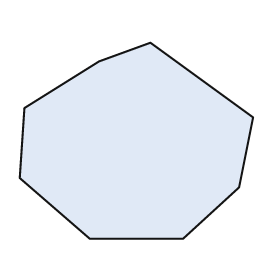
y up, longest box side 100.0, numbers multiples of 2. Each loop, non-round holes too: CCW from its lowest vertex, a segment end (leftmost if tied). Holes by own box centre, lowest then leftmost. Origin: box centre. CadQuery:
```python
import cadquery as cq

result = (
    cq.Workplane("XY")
    .moveTo(-20.0, -42.0)
    .lineTo(20.0, -42.0)
    .lineTo(44.0, -20.0)
    .lineTo(50.0, 10.0)
    .lineTo(6.0, 42.0)
    .lineTo(-16.0, 34.0)
    .lineTo(-48.0, 14.0)
    .lineTo(-50.0, -16.0)
    .close()
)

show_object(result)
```